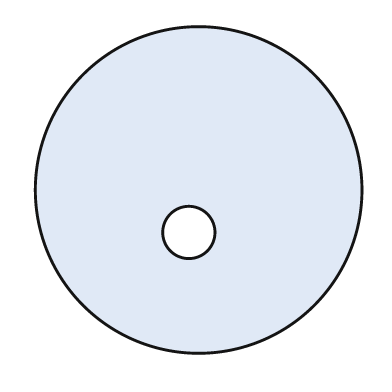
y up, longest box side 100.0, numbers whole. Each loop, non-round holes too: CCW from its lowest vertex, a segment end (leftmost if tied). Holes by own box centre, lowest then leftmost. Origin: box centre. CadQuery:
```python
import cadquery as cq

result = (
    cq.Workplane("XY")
    .moveTo(0.0, 0.0)
    .circle(50.0)
    .moveTo(-3.0, -13.0)
    .circle(8.0)
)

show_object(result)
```